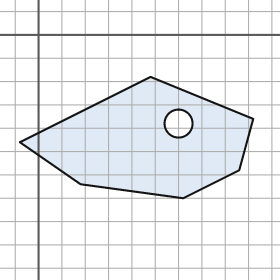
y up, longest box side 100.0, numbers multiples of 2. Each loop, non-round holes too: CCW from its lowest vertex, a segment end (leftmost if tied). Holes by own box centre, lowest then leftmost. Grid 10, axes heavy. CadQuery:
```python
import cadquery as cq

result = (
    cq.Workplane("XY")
    .moveTo(62.0, -70.0)
    .lineTo(86.0, -58.0)
    .lineTo(92.0, -36.0)
    .lineTo(48.0, -18.0)
    .lineTo(-8.0, -46.0)
    .lineTo(18.0, -64.0)
    .close()
    .moveTo(60.0, -38.0)
    .circle(6.0)
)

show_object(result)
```